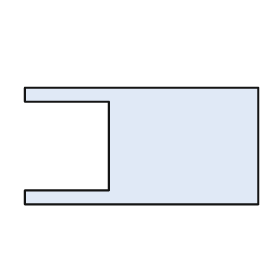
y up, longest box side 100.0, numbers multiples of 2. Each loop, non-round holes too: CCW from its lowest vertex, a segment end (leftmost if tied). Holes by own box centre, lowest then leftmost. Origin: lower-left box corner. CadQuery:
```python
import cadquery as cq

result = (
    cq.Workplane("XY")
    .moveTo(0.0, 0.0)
    .lineTo(100.0, 0.0)
    .lineTo(100.0, 50.0)
    .lineTo(0.0, 50.0)
    .lineTo(0.0, 44.0)
    .lineTo(36.0, 44.0)
    .lineTo(36.0, 6.0)
    .lineTo(0.0, 6.0)
    .close()
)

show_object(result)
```